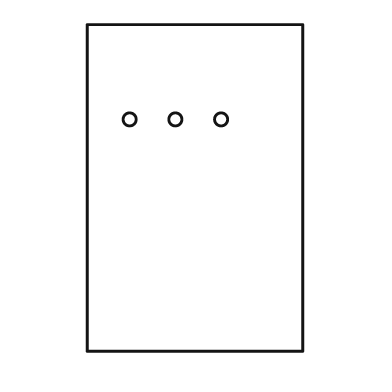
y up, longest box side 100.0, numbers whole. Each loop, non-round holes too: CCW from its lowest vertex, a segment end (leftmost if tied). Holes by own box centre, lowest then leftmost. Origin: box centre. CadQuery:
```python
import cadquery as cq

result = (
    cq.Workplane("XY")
    .moveTo(-33.0, -50.0)
    .lineTo(33.0, -50.0)
    .lineTo(33.0, 50.0)
    .lineTo(-33.0, 50.0)
    .close()
    .moveTo(-20.0, 21.0)
    .circle(2.0)
    .moveTo(-6.0, 21.0)
    .circle(2.0)
    .moveTo(8.0, 21.0)
    .circle(2.0)
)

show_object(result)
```